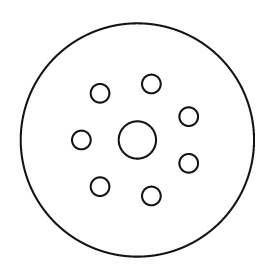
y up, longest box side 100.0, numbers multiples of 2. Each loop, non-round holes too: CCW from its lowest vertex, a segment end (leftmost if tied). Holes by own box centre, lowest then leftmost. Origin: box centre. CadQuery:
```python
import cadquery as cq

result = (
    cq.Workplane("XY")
    .moveTo(0.0, 0.0)
    .circle(50.0)
    .moveTo(6.0, -24.0)
    .circle(4.0)
    .moveTo(-16.0, -20.0)
    .circle(4.0)
    .moveTo(22.0, -10.0)
    .circle(4.0)
    .moveTo(-24.0, 0.0)
    .circle(4.0)
    .moveTo(0.0, 0.0)
    .circle(8.0)
    .moveTo(22.0, 10.0)
    .circle(4.0)
    .moveTo(-16.0, 20.0)
    .circle(4.0)
    .moveTo(6.0, 24.0)
    .circle(4.0)
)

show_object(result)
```